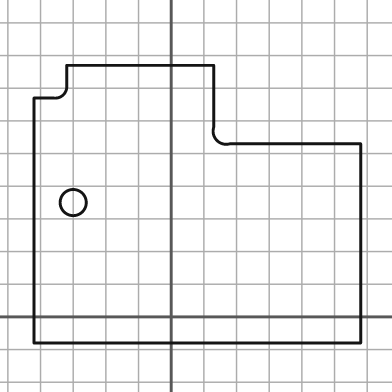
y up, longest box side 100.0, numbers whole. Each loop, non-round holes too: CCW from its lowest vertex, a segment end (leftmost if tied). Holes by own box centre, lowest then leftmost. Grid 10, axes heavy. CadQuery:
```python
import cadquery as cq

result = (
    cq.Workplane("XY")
    .moveTo(-42.0, -8.0)
    .lineTo(58.0, -8.0)
    .lineTo(58.0, 53.0)
    .lineTo(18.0, 53.0)
    .threePointArc((14.0, 54.0), (13.0, 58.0))
    .lineTo(13.0, 77.0)
    .lineTo(-32.0, 77.0)
    .lineTo(-32.0, 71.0)
    .threePointArc((-33.0, 68.0), (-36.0, 67.0))
    .lineTo(-42.0, 67.0)
    .close()
    .moveTo(-30.0, 35.0)
    .circle(4.0)
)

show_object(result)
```